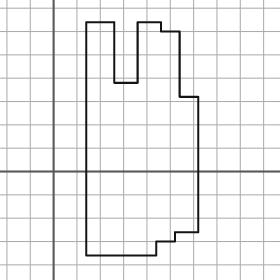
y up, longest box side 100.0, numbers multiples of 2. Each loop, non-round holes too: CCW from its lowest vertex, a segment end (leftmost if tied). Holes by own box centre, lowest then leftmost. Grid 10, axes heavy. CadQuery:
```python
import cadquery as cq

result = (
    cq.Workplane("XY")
    .moveTo(14.0, -36.0)
    .lineTo(44.0, -36.0)
    .lineTo(44.0, -30.0)
    .lineTo(52.0, -30.0)
    .lineTo(52.0, -26.0)
    .lineTo(62.0, -26.0)
    .lineTo(62.0, 32.0)
    .lineTo(54.0, 32.0)
    .lineTo(54.0, 60.0)
    .lineTo(46.0, 60.0)
    .lineTo(46.0, 64.0)
    .lineTo(36.0, 64.0)
    .lineTo(36.0, 38.0)
    .lineTo(26.0, 38.0)
    .lineTo(26.0, 64.0)
    .lineTo(14.0, 64.0)
    .close()
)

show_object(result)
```